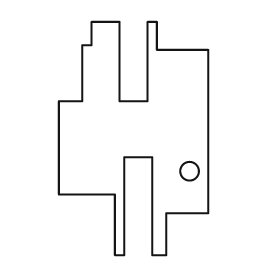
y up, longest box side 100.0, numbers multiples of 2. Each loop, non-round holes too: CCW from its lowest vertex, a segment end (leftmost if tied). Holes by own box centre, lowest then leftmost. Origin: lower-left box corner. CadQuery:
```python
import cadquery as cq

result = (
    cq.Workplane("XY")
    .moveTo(24.0, 0.0)
    .lineTo(28.0, 0.0)
    .lineTo(28.0, 42.0)
    .lineTo(40.0, 42.0)
    .lineTo(40.0, 0.0)
    .lineTo(46.0, 0.0)
    .lineTo(46.0, 18.0)
    .lineTo(64.0, 18.0)
    .lineTo(64.0, 88.0)
    .lineTo(42.0, 88.0)
    .lineTo(42.0, 100.0)
    .lineTo(38.0, 100.0)
    .lineTo(38.0, 66.0)
    .lineTo(26.0, 66.0)
    .lineTo(26.0, 100.0)
    .lineTo(14.0, 100.0)
    .lineTo(14.0, 90.0)
    .lineTo(10.0, 90.0)
    .lineTo(10.0, 66.0)
    .lineTo(0.0, 66.0)
    .lineTo(0.0, 26.0)
    .lineTo(24.0, 26.0)
    .close()
    .moveTo(56.0, 36.0)
    .circle(4.0)
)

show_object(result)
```